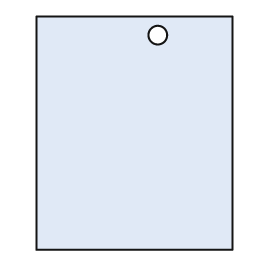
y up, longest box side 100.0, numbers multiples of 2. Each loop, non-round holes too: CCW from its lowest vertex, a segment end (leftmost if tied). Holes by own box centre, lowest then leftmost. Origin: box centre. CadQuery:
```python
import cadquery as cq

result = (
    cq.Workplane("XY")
    .moveTo(-42.0, -50.0)
    .lineTo(42.0, -50.0)
    .lineTo(42.0, 50.0)
    .lineTo(-42.0, 50.0)
    .close()
    .moveTo(10.0, 42.0)
    .circle(4.0)
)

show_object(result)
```